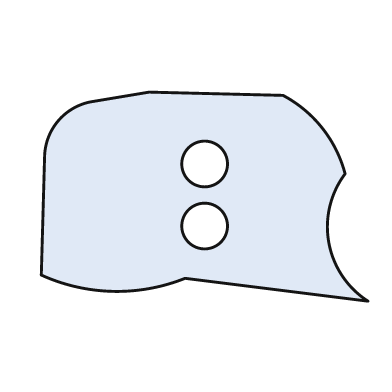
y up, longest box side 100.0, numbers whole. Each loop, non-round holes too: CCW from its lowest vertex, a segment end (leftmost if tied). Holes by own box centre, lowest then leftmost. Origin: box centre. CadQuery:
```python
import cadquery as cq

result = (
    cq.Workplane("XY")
    .moveTo(50.0, -32.0)
    .threePointArc((38.0, -14.0), (43.0, 7.0))
    .threePointArc((36.0, 21.0), (24.0, 31.0))
    .lineTo(-17.0, 32.0)
    .lineTo(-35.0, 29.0)
    .threePointArc((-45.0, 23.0), (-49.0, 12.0))
    .lineTo(-50.0, -24.0)
    .threePointArc((-28.0, -29.0), (-6.0, -25.0))
    .close()
    .moveTo(0.0, -9.0)
    .circle(7.0)
    .moveTo(0.0, 10.0)
    .circle(7.0)
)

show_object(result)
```